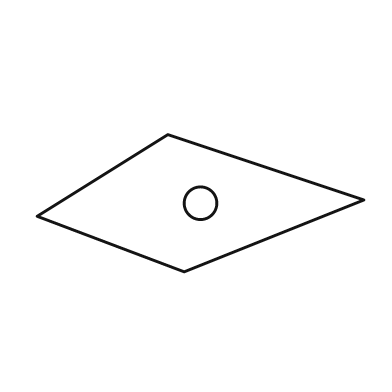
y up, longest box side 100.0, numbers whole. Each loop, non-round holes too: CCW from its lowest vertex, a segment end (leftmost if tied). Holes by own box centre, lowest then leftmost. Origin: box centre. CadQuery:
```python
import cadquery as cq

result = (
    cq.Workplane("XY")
    .moveTo(-5.0, -21.0)
    .lineTo(50.0, 1.0)
    .lineTo(-10.0, 21.0)
    .lineTo(-50.0, -4.0)
    .close()
    .moveTo(0.0, 0.0)
    .circle(5.0)
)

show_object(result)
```